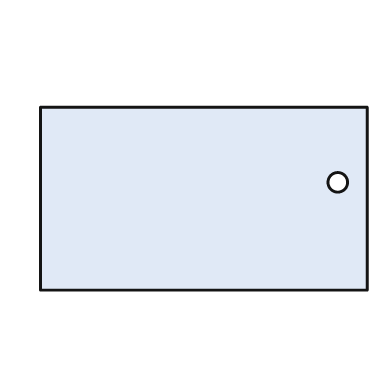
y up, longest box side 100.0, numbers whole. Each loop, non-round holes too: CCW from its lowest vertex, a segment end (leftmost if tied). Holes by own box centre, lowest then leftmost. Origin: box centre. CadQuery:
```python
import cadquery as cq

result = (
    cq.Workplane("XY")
    .moveTo(-50.0, -28.0)
    .lineTo(50.0, -28.0)
    .lineTo(50.0, 28.0)
    .lineTo(-50.0, 28.0)
    .close()
    .moveTo(41.0, 5.0)
    .circle(3.0)
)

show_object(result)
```